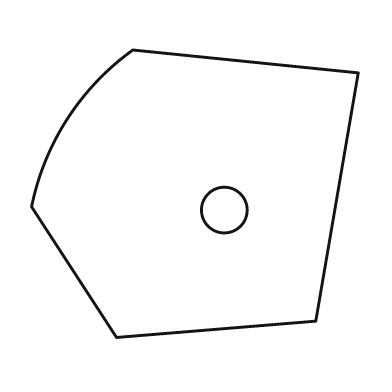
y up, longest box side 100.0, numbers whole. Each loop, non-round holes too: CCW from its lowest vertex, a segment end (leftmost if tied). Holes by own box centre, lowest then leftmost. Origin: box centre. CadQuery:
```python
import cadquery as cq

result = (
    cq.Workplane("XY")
    .moveTo(-24.0, -44.0)
    .lineTo(37.0, -39.0)
    .lineTo(50.0, 37.0)
    .lineTo(-19.0, 44.0)
    .threePointArc((-39.0, 23.0), (-50.0, -4.0))
    .close()
    .moveTo(9.0, -5.0)
    .circle(7.0)
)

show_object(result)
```